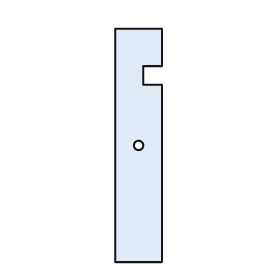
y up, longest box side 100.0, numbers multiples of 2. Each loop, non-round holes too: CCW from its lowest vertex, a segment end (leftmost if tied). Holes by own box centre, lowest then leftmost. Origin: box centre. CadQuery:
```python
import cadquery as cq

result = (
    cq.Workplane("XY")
    .moveTo(-10.0, -50.0)
    .lineTo(10.0, -50.0)
    .lineTo(10.0, 26.0)
    .lineTo(2.0, 26.0)
    .lineTo(2.0, 34.0)
    .lineTo(10.0, 34.0)
    .lineTo(10.0, 50.0)
    .lineTo(-10.0, 50.0)
    .close()
    .moveTo(0.0, 0.0)
    .circle(2.0)
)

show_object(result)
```